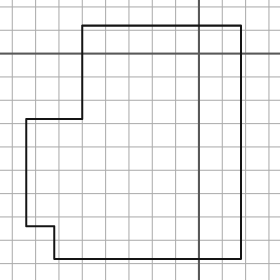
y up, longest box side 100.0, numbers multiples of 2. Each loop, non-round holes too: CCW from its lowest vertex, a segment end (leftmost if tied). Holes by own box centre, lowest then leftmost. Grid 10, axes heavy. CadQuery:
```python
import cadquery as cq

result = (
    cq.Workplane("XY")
    .moveTo(-62.0, -88.0)
    .lineTo(18.0, -88.0)
    .lineTo(18.0, 12.0)
    .lineTo(-50.0, 12.0)
    .lineTo(-50.0, -28.0)
    .lineTo(-74.0, -28.0)
    .lineTo(-74.0, -74.0)
    .lineTo(-62.0, -74.0)
    .close()
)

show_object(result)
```